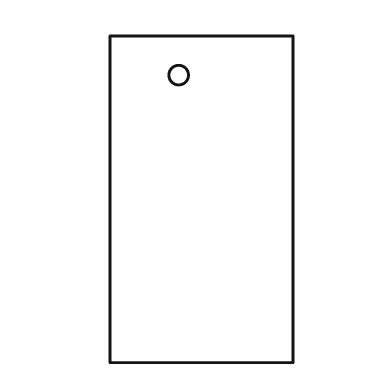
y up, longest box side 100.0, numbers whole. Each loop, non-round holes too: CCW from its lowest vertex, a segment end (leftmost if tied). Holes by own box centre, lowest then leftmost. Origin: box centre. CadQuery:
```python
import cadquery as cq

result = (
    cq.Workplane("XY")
    .moveTo(-28.0, -50.0)
    .lineTo(28.0, -50.0)
    .lineTo(28.0, 50.0)
    .lineTo(-28.0, 50.0)
    .close()
    .moveTo(-7.0, 38.0)
    .circle(3.0)
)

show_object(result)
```